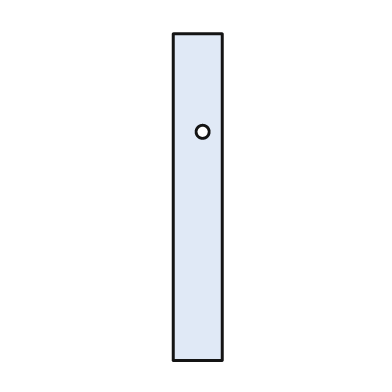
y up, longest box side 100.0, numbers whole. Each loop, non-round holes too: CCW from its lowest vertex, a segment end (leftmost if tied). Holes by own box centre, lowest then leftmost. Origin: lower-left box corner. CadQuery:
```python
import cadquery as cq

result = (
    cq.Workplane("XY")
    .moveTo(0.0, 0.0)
    .lineTo(15.0, 0.0)
    .lineTo(15.0, 100.0)
    .lineTo(0.0, 100.0)
    .close()
    .moveTo(9.0, 70.0)
    .circle(2.0)
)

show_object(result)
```